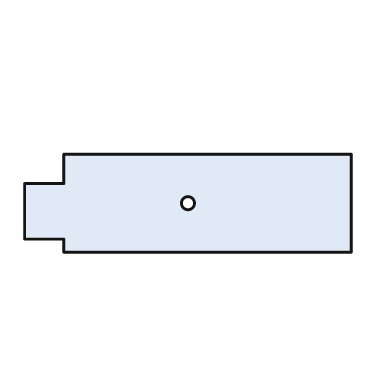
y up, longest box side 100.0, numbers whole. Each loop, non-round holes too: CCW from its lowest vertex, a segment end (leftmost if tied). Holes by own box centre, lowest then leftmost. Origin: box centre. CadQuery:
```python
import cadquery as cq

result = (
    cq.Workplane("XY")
    .moveTo(-38.0, -15.0)
    .lineTo(50.0, -15.0)
    .lineTo(50.0, 15.0)
    .lineTo(-38.0, 15.0)
    .lineTo(-38.0, 6.0)
    .lineTo(-50.0, 6.0)
    .lineTo(-50.0, -11.0)
    .lineTo(-38.0, -11.0)
    .close()
    .moveTo(0.0, 0.0)
    .circle(2.0)
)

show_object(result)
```